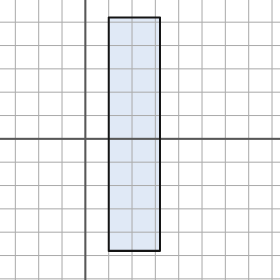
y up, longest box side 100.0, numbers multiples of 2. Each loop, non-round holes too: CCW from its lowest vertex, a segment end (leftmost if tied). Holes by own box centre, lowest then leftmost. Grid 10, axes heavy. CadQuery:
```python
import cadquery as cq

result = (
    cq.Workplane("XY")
    .moveTo(10.0, -48.0)
    .lineTo(32.0, -48.0)
    .lineTo(32.0, 52.0)
    .lineTo(10.0, 52.0)
    .close()
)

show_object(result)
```